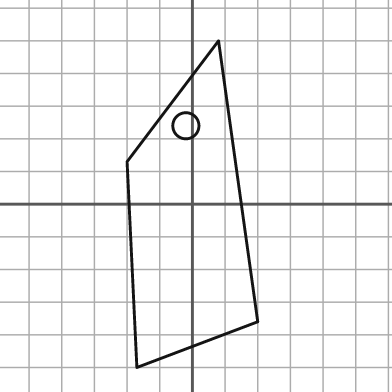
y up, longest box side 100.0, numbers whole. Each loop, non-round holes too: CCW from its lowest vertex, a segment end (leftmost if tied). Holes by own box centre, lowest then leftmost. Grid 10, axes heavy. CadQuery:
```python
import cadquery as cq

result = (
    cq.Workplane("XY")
    .moveTo(-17.0, -50.0)
    .lineTo(20.0, -36.0)
    .lineTo(8.0, 50.0)
    .lineTo(-20.0, 13.0)
    .close()
    .moveTo(-2.0, 24.0)
    .circle(4.0)
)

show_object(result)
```